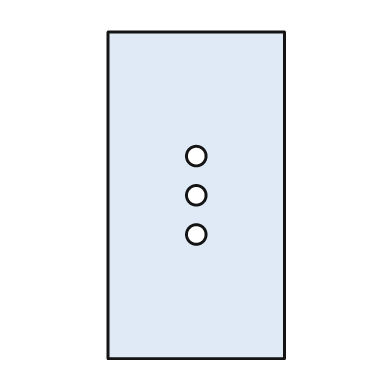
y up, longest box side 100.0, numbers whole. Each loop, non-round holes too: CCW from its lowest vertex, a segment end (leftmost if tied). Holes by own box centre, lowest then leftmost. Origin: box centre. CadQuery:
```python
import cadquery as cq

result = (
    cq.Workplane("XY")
    .moveTo(-27.0, -50.0)
    .lineTo(27.0, -50.0)
    .lineTo(27.0, 50.0)
    .lineTo(-27.0, 50.0)
    .close()
    .moveTo(0.0, -12.0)
    .circle(3.0)
    .moveTo(0.0, 0.0)
    .circle(3.0)
    .moveTo(0.0, 12.0)
    .circle(3.0)
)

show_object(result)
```